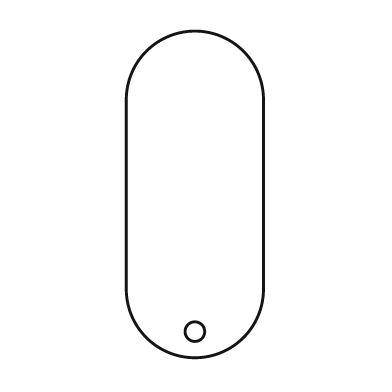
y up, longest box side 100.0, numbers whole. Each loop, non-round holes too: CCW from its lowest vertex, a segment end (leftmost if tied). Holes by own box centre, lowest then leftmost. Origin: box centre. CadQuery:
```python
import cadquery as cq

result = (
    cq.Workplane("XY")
    .moveTo(-21.0, -29.0)
    .threePointArc((0.0, -50.0), (21.0, -29.0))
    .lineTo(21.0, 29.0)
    .threePointArc((0.0, 50.0), (-21.0, 29.0))
    .close()
    .moveTo(0.0, -42.0)
    .circle(3.0)
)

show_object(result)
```